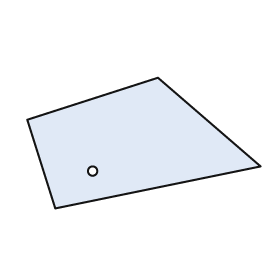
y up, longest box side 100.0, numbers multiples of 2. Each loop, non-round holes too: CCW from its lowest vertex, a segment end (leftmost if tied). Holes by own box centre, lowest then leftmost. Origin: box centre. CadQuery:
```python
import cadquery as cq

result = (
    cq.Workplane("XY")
    .moveTo(-38.0, -28.0)
    .lineTo(50.0, -10.0)
    .lineTo(6.0, 28.0)
    .lineTo(-50.0, 10.0)
    .close()
    .moveTo(-22.0, -12.0)
    .circle(2.0)
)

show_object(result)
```